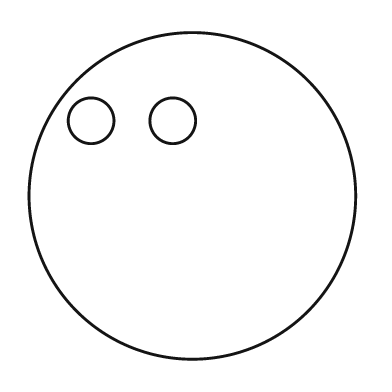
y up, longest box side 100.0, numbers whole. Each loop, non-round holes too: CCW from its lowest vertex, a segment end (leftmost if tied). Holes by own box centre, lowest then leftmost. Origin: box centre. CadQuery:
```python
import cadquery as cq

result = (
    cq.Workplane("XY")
    .moveTo(0.0, 0.0)
    .circle(50.0)
    .moveTo(-31.0, 23.0)
    .circle(7.0)
    .moveTo(-6.0, 23.0)
    .circle(7.0)
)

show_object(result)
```